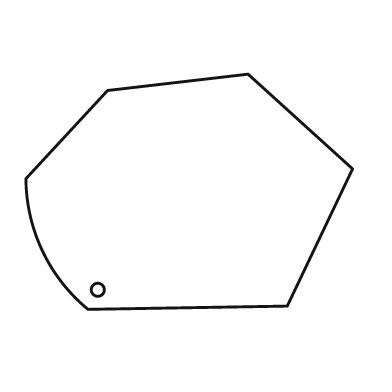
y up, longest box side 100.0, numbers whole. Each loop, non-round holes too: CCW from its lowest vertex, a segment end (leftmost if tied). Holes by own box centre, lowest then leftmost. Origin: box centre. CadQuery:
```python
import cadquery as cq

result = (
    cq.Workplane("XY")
    .moveTo(-31.0, -36.0)
    .lineTo(30.0, -35.0)
    .lineTo(50.0, 7.0)
    .lineTo(18.0, 36.0)
    .lineTo(-25.0, 31.0)
    .lineTo(-50.0, 4.0)
    .threePointArc((-45.0, -18.0), (-31.0, -36.0))
    .close()
    .moveTo(-28.0, -30.0)
    .circle(2.0)
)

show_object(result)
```